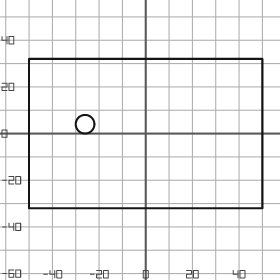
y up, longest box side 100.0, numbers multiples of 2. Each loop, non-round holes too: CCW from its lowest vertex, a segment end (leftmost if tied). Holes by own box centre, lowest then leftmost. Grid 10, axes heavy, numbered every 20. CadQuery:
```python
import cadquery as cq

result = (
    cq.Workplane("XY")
    .moveTo(-50.0, -32.0)
    .lineTo(50.0, -32.0)
    .lineTo(50.0, 32.0)
    .lineTo(-50.0, 32.0)
    .close()
    .moveTo(-26.0, 4.0)
    .circle(4.0)
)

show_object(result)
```